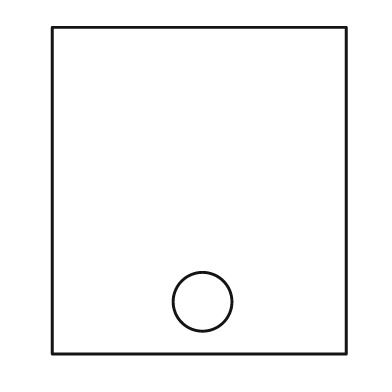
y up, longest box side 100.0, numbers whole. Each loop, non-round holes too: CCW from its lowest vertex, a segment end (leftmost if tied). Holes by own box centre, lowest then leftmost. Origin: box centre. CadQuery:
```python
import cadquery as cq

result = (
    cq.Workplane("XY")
    .moveTo(-45.0, -50.0)
    .lineTo(45.0, -50.0)
    .lineTo(45.0, 50.0)
    .lineTo(-45.0, 50.0)
    .close()
    .moveTo(1.0, -34.0)
    .circle(9.0)
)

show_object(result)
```